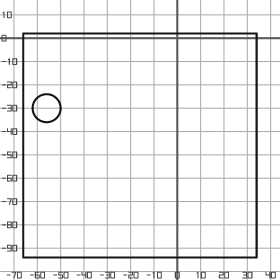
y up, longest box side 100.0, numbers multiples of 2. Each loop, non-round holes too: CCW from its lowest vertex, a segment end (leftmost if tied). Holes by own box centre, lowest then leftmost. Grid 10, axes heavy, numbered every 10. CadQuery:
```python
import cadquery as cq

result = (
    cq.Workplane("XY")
    .moveTo(-66.0, -94.0)
    .lineTo(34.0, -94.0)
    .lineTo(34.0, 2.0)
    .lineTo(-66.0, 2.0)
    .close()
    .moveTo(-56.0, -30.0)
    .circle(6.0)
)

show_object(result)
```